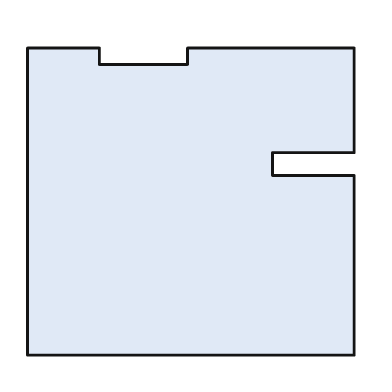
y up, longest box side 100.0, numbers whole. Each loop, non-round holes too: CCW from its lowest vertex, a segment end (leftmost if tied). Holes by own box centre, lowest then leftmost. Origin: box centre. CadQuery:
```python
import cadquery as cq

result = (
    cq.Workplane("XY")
    .moveTo(-50.0, -47.0)
    .lineTo(50.0, -47.0)
    .lineTo(50.0, 8.0)
    .lineTo(25.0, 8.0)
    .lineTo(25.0, 15.0)
    .lineTo(50.0, 15.0)
    .lineTo(50.0, 47.0)
    .lineTo(-1.0, 47.0)
    .lineTo(-1.0, 42.0)
    .lineTo(-28.0, 42.0)
    .lineTo(-28.0, 47.0)
    .lineTo(-50.0, 47.0)
    .close()
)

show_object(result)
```